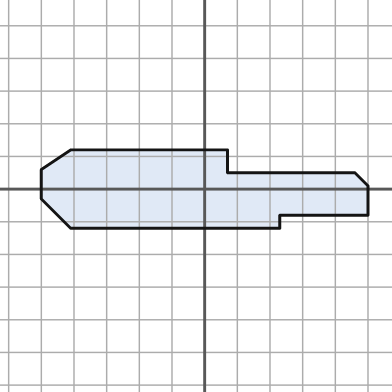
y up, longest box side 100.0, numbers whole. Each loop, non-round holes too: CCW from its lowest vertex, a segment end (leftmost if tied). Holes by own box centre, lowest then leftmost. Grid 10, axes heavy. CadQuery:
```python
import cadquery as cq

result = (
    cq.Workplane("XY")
    .moveTo(-41.0, -12.0)
    .lineTo(23.0, -12.0)
    .lineTo(23.0, -8.0)
    .lineTo(50.0, -8.0)
    .lineTo(50.0, 1.0)
    .lineTo(46.0, 5.0)
    .lineTo(7.0, 5.0)
    .lineTo(7.0, 12.0)
    .lineTo(-41.0, 12.0)
    .lineTo(-50.0, 6.0)
    .lineTo(-50.0, -3.0)
    .close()
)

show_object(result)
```